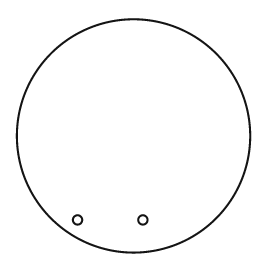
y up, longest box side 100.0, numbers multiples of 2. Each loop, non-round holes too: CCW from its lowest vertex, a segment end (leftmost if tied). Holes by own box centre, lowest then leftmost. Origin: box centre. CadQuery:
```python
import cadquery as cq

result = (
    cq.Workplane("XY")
    .moveTo(0.0, 0.0)
    .circle(50.0)
    .moveTo(-24.0, -36.0)
    .circle(2.0)
    .moveTo(4.0, -36.0)
    .circle(2.0)
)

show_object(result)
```